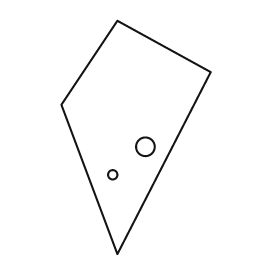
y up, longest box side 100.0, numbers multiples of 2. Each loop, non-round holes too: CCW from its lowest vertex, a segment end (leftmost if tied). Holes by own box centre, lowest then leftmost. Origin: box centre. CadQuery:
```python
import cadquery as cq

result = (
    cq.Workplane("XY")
    .moveTo(-8.0, -50.0)
    .lineTo(32.0, 28.0)
    .lineTo(-8.0, 50.0)
    .lineTo(-32.0, 14.0)
    .close()
    .moveTo(-10.0, -16.0)
    .circle(2.0)
    .moveTo(4.0, -4.0)
    .circle(4.0)
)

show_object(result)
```